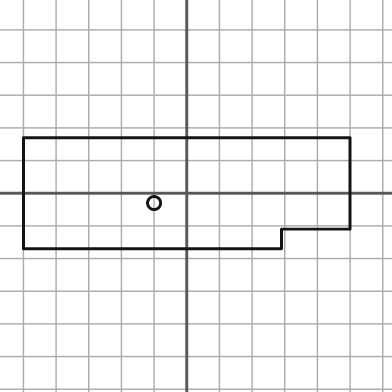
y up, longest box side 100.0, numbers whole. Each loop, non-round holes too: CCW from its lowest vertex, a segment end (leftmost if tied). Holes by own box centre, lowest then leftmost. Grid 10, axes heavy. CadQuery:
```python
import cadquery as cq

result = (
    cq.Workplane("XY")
    .moveTo(-50.0, -17.0)
    .lineTo(29.0, -17.0)
    .lineTo(29.0, -11.0)
    .lineTo(50.0, -11.0)
    .lineTo(50.0, 17.0)
    .lineTo(-50.0, 17.0)
    .close()
    .moveTo(-10.0, -3.0)
    .circle(2.0)
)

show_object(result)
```